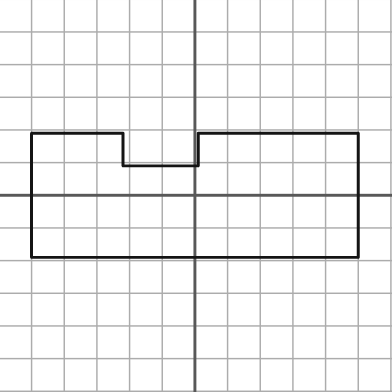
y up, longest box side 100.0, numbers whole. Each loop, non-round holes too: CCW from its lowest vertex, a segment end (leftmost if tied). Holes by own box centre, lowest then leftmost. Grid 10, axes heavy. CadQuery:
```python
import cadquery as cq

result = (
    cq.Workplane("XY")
    .moveTo(-50.0, -19.0)
    .lineTo(50.0, -19.0)
    .lineTo(50.0, 19.0)
    .lineTo(1.0, 19.0)
    .lineTo(1.0, 9.0)
    .lineTo(-22.0, 9.0)
    .lineTo(-22.0, 19.0)
    .lineTo(-50.0, 19.0)
    .close()
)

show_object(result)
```